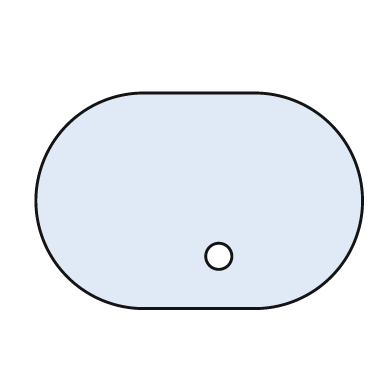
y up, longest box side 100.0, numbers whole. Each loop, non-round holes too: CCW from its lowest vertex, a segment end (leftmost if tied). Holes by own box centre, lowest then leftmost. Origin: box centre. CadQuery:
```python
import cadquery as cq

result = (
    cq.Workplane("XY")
    .moveTo(-17.0, -33.0)
    .lineTo(17.0, -33.0)
    .threePointArc((50.0, 0.0), (17.0, 33.0))
    .lineTo(-17.0, 33.0)
    .threePointArc((-50.0, 0.0), (-17.0, -33.0))
    .close()
    .moveTo(6.0, -17.0)
    .circle(4.0)
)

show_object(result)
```